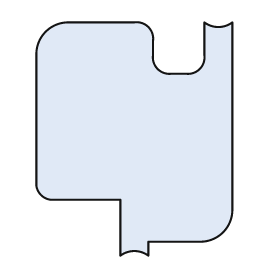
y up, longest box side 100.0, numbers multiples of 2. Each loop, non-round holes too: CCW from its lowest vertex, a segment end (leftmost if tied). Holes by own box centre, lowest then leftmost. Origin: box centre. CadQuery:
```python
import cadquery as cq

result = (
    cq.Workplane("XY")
    .moveTo(-6.0, -50.0)
    .threePointArc((0.0, -48.0), (6.0, -50.0))
    .lineTo(6.0, -44.0)
    .lineTo(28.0, -44.0)
    .threePointArc((38.0, -40.0), (42.0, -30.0))
    .lineTo(42.0, 50.0)
    .threePointArc((36.0, 48.0), (30.0, 50.0))
    .lineTo(30.0, 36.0)
    .threePointArc((28.0, 30.0), (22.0, 28.0))
    .lineTo(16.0, 28.0)
    .threePointArc((10.0, 30.0), (8.0, 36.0))
    .lineTo(8.0, 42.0)
    .threePointArc((6.0, 48.0), (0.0, 50.0))
    .lineTo(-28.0, 50.0)
    .threePointArc((-38.0, 46.0), (-42.0, 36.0))
    .lineTo(-42.0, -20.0)
    .threePointArc((-40.0, -24.0), (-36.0, -26.0))
    .lineTo(-6.0, -26.0)
    .close()
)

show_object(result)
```